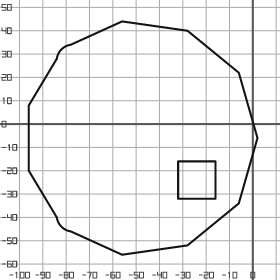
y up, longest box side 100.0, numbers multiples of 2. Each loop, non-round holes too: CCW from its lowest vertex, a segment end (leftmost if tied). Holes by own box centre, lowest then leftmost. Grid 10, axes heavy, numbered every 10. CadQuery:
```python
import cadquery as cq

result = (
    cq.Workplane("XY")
    .moveTo(-56.0, -56.0)
    .lineTo(-28.0, -52.0)
    .lineTo(-6.0, -34.0)
    .lineTo(2.0, -6.0)
    .lineTo(-6.0, 22.0)
    .lineTo(-28.0, 40.0)
    .lineTo(-56.0, 44.0)
    .lineTo(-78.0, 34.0)
    .threePointArc((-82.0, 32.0), (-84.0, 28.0))
    .lineTo(-96.0, 8.0)
    .lineTo(-96.0, -20.0)
    .lineTo(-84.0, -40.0)
    .threePointArc((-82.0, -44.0), (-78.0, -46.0))
    .close()
    .moveTo(-32.0, -32.0)
    .lineTo(-16.0, -32.0)
    .lineTo(-16.0, -16.0)
    .lineTo(-32.0, -16.0)
    .close()
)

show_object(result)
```